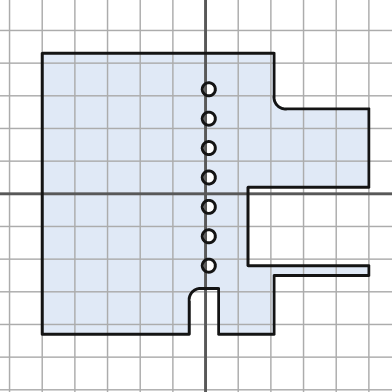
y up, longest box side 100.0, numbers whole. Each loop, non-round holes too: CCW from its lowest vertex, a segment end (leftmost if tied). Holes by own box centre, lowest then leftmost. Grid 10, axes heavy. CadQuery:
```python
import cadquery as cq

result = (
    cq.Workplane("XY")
    .moveTo(-50.0, -43.0)
    .lineTo(-5.0, -43.0)
    .lineTo(-5.0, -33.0)
    .threePointArc((-4.0, -30.0), (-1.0, -29.0))
    .lineTo(4.0, -29.0)
    .lineTo(4.0, -43.0)
    .lineTo(21.0, -43.0)
    .lineTo(21.0, -25.0)
    .lineTo(50.0, -25.0)
    .lineTo(50.0, -22.0)
    .lineTo(13.0, -22.0)
    .lineTo(13.0, 2.0)
    .lineTo(50.0, 2.0)
    .lineTo(50.0, 26.0)
    .lineTo(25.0, 26.0)
    .threePointArc((22.0, 27.0), (21.0, 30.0))
    .lineTo(21.0, 43.0)
    .lineTo(-50.0, 43.0)
    .close()
    .moveTo(1.0, -22.0)
    .circle(2.0)
    .moveTo(1.0, -13.0)
    .circle(2.0)
    .moveTo(1.0, -4.0)
    .circle(2.0)
    .moveTo(1.0, 5.0)
    .circle(2.0)
    .moveTo(1.0, 14.0)
    .circle(2.0)
    .moveTo(1.0, 23.0)
    .circle(2.0)
    .moveTo(1.0, 32.0)
    .circle(2.0)
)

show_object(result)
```